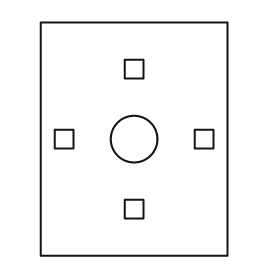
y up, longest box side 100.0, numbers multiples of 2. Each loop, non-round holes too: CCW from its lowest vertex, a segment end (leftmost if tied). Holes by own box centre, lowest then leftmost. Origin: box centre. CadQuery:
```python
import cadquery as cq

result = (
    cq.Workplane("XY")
    .moveTo(-40.0, -50.0)
    .lineTo(40.0, -50.0)
    .lineTo(40.0, 50.0)
    .lineTo(-40.0, 50.0)
    .close()
    .moveTo(-4.0, -34.0)
    .lineTo(4.0, -34.0)
    .lineTo(4.0, -26.0)
    .lineTo(-4.0, -26.0)
    .close()
    .moveTo(-34.0, -4.0)
    .lineTo(-26.0, -4.0)
    .lineTo(-26.0, 4.0)
    .lineTo(-34.0, 4.0)
    .close()
    .moveTo(0.0, 0.0)
    .circle(10.0)
    .moveTo(26.0, -4.0)
    .lineTo(34.0, -4.0)
    .lineTo(34.0, 4.0)
    .lineTo(26.0, 4.0)
    .close()
    .moveTo(-4.0, 26.0)
    .lineTo(4.0, 26.0)
    .lineTo(4.0, 34.0)
    .lineTo(-4.0, 34.0)
    .close()
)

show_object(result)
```